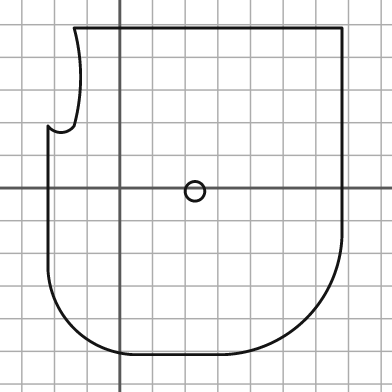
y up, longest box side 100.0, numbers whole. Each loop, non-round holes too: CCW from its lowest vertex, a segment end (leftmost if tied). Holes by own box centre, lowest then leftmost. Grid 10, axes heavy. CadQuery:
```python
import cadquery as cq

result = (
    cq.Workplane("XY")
    .moveTo(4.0, -51.0)
    .lineTo(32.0, -51.0)
    .threePointArc((57.0, -40.0), (68.0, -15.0))
    .lineTo(68.0, 49.0)
    .lineTo(-14.0, 49.0)
    .threePointArc((-12.0, 34.0), (-14.0, 19.0))
    .threePointArc((-18.0, 17.0), (-22.0, 19.0))
    .lineTo(-22.0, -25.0)
    .threePointArc((-14.0, -43.0), (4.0, -51.0))
    .close()
    .moveTo(23.0, -1.0)
    .circle(3.0)
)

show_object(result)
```